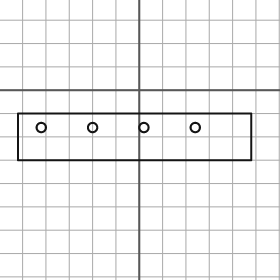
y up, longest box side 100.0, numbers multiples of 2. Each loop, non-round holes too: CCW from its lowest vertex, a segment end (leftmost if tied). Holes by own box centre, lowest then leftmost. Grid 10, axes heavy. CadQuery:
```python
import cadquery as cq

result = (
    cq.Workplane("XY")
    .moveTo(-52.0, -30.0)
    .lineTo(48.0, -30.0)
    .lineTo(48.0, -10.0)
    .lineTo(-52.0, -10.0)
    .close()
    .moveTo(-42.0, -16.0)
    .circle(2.0)
    .moveTo(-20.0, -16.0)
    .circle(2.0)
    .moveTo(2.0, -16.0)
    .circle(2.0)
    .moveTo(24.0, -16.0)
    .circle(2.0)
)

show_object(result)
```